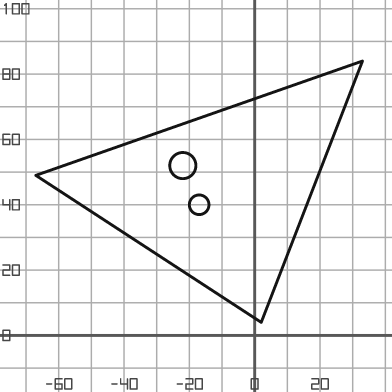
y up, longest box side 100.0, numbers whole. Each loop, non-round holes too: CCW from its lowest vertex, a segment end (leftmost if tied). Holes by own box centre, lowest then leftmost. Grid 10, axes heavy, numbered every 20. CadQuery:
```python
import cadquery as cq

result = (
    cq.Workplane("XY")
    .moveTo(2.0, 4.0)
    .lineTo(33.0, 84.0)
    .lineTo(-67.0, 49.0)
    .close()
    .moveTo(-17.0, 40.0)
    .circle(3.0)
    .moveTo(-22.0, 52.0)
    .circle(4.0)
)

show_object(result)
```